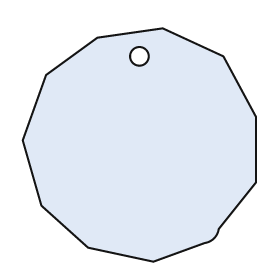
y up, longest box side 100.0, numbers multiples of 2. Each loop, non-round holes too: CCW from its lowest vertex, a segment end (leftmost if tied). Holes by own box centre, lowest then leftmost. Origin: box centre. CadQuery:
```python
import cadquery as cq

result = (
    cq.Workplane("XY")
    .moveTo(6.0, -50.0)
    .lineTo(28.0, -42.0)
    .threePointArc((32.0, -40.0), (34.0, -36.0))
    .lineTo(50.0, -16.0)
    .lineTo(50.0, 12.0)
    .lineTo(36.0, 38.0)
    .lineTo(10.0, 50.0)
    .lineTo(-18.0, 46.0)
    .lineTo(-40.0, 30.0)
    .lineTo(-50.0, 2.0)
    .lineTo(-42.0, -26.0)
    .lineTo(-22.0, -44.0)
    .close()
    .moveTo(0.0, 38.0)
    .circle(4.0)
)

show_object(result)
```